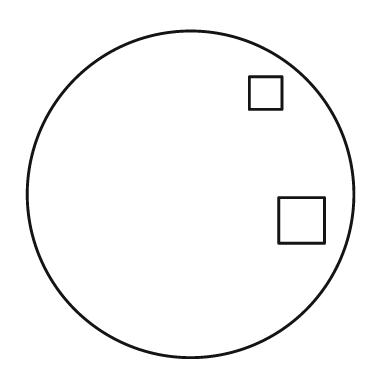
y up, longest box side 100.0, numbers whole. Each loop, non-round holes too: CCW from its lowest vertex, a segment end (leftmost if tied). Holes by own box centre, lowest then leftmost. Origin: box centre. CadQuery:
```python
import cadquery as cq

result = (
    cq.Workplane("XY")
    .moveTo(0.0, 0.0)
    .circle(50.0)
    .moveTo(27.0, -15.0)
    .lineTo(41.0, -15.0)
    .lineTo(41.0, -1.0)
    .lineTo(27.0, -1.0)
    .close()
    .moveTo(18.0, 26.0)
    .lineTo(28.0, 26.0)
    .lineTo(28.0, 36.0)
    .lineTo(18.0, 36.0)
    .close()
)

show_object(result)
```